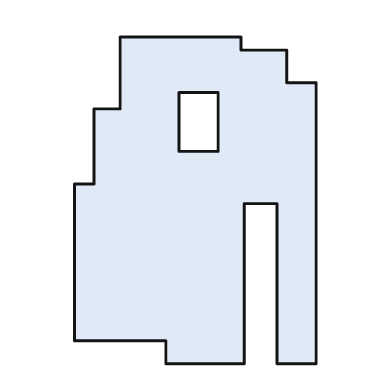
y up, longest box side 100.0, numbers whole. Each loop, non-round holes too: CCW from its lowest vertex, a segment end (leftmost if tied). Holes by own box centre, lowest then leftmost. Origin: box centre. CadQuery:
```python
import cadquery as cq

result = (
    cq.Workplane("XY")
    .moveTo(-9.0, -50.0)
    .lineTo(15.0, -50.0)
    .lineTo(15.0, -1.0)
    .lineTo(25.0, -1.0)
    .lineTo(25.0, -50.0)
    .lineTo(37.0, -50.0)
    .lineTo(37.0, 36.0)
    .lineTo(28.0, 36.0)
    .lineTo(28.0, 46.0)
    .lineTo(14.0, 46.0)
    .lineTo(14.0, 50.0)
    .lineTo(-23.0, 50.0)
    .lineTo(-23.0, 28.0)
    .lineTo(-31.0, 28.0)
    .lineTo(-31.0, 5.0)
    .lineTo(-37.0, 5.0)
    .lineTo(-37.0, -43.0)
    .lineTo(-9.0, -43.0)
    .close()
    .moveTo(-5.0, 15.0)
    .lineTo(7.0, 15.0)
    .lineTo(7.0, 33.0)
    .lineTo(-5.0, 33.0)
    .close()
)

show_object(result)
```